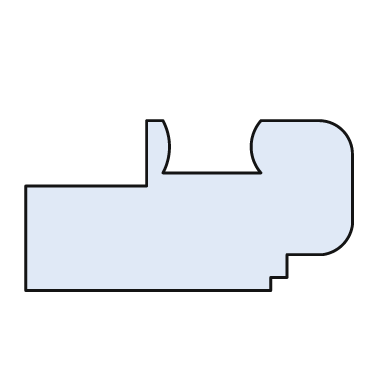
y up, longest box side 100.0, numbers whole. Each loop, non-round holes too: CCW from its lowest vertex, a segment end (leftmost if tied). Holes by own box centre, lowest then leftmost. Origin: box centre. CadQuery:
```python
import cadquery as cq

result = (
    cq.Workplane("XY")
    .moveTo(-50.0, -26.0)
    .lineTo(25.0, -26.0)
    .lineTo(25.0, -22.0)
    .lineTo(30.0, -22.0)
    .lineTo(30.0, -15.0)
    .lineTo(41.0, -15.0)
    .threePointArc((47.0, -12.0), (50.0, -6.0))
    .lineTo(50.0, 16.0)
    .threePointArc((47.0, 23.0), (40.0, 26.0))
    .lineTo(22.0, 26.0)
    .threePointArc((19.0, 18.0), (22.0, 10.0))
    .lineTo(-8.0, 10.0)
    .threePointArc((-6.0, 18.0), (-8.0, 26.0))
    .lineTo(-13.0, 26.0)
    .lineTo(-13.0, 6.0)
    .lineTo(-50.0, 6.0)
    .close()
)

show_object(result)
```